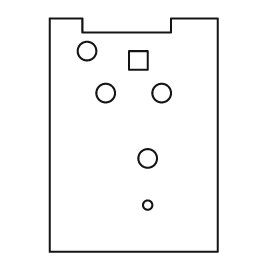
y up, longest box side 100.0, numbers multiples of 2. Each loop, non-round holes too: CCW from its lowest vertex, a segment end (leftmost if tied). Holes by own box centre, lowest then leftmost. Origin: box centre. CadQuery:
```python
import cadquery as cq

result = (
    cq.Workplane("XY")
    .moveTo(-36.0, -50.0)
    .lineTo(36.0, -50.0)
    .lineTo(36.0, 50.0)
    .lineTo(16.0, 50.0)
    .lineTo(16.0, 44.0)
    .lineTo(-22.0, 44.0)
    .lineTo(-22.0, 50.0)
    .lineTo(-36.0, 50.0)
    .close()
    .moveTo(6.0, -30.0)
    .circle(2.0)
    .moveTo(6.0, -10.0)
    .circle(4.0)
    .moveTo(-12.0, 18.0)
    .circle(4.0)
    .moveTo(12.0, 18.0)
    .circle(4.0)
    .moveTo(-2.0, 28.0)
    .lineTo(6.0, 28.0)
    .lineTo(6.0, 36.0)
    .lineTo(-2.0, 36.0)
    .close()
    .moveTo(-20.0, 36.0)
    .circle(4.0)
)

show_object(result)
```